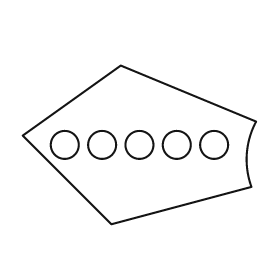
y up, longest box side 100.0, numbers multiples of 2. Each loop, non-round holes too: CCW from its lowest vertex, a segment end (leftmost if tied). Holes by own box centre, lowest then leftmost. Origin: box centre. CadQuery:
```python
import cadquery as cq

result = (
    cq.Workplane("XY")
    .moveTo(-12.0, -34.0)
    .lineTo(48.0, -18.0)
    .threePointArc((46.0, -4.0), (50.0, 10.0))
    .lineTo(-8.0, 34.0)
    .lineTo(-50.0, 4.0)
    .close()
    .moveTo(-32.0, 0.0)
    .circle(6.0)
    .moveTo(-16.0, 0.0)
    .circle(6.0)
    .moveTo(0.0, 0.0)
    .circle(6.0)
    .moveTo(16.0, 0.0)
    .circle(6.0)
    .moveTo(32.0, 0.0)
    .circle(6.0)
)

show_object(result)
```